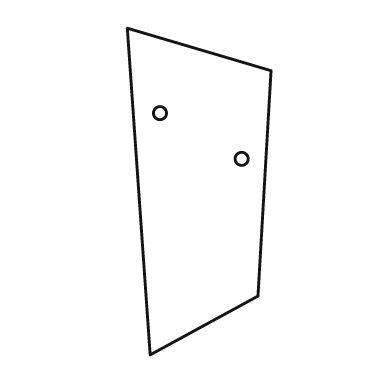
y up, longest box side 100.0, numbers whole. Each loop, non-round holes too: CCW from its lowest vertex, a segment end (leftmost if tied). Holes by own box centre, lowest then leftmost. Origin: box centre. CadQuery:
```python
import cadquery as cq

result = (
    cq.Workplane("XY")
    .moveTo(-15.0, -50.0)
    .lineTo(18.0, -32.0)
    .lineTo(22.0, 37.0)
    .lineTo(-22.0, 50.0)
    .close()
    .moveTo(13.0, 10.0)
    .circle(2.0)
    .moveTo(-12.0, 24.0)
    .circle(2.0)
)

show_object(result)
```